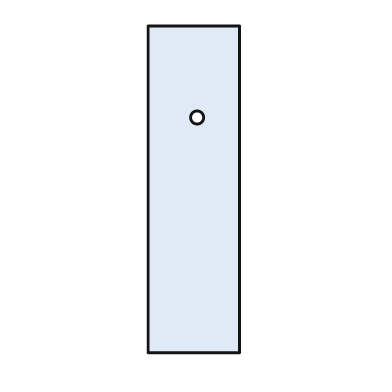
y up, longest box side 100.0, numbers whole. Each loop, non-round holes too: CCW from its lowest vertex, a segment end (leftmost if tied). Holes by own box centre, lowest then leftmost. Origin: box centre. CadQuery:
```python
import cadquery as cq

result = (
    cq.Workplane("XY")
    .moveTo(-14.0, -50.0)
    .lineTo(14.0, -50.0)
    .lineTo(14.0, 50.0)
    .lineTo(-14.0, 50.0)
    .close()
    .moveTo(1.0, 22.0)
    .circle(2.0)
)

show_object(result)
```